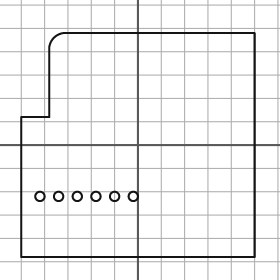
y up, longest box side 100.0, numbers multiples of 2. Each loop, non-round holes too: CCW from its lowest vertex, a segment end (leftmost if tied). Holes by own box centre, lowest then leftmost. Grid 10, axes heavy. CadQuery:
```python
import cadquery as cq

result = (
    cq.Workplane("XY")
    .moveTo(-50.0, -48.0)
    .lineTo(50.0, -48.0)
    .lineTo(50.0, 48.0)
    .lineTo(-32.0, 48.0)
    .threePointArc((-36.0, 46.0), (-38.0, 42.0))
    .lineTo(-38.0, 12.0)
    .lineTo(-50.0, 12.0)
    .close()
    .moveTo(-42.0, -22.0)
    .circle(2.0)
    .moveTo(-34.0, -22.0)
    .circle(2.0)
    .moveTo(-26.0, -22.0)
    .circle(2.0)
    .moveTo(-18.0, -22.0)
    .circle(2.0)
    .moveTo(-10.0, -22.0)
    .circle(2.0)
    .moveTo(-2.0, -22.0)
    .circle(2.0)
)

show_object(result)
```